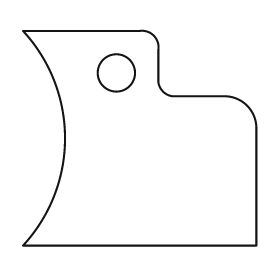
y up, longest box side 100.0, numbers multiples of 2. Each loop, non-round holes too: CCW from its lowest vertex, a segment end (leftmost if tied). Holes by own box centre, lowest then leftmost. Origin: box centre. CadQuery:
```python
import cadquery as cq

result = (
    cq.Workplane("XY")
    .moveTo(-50.0, -46.0)
    .lineTo(50.0, -46.0)
    .lineTo(50.0, 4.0)
    .threePointArc((46.0, 14.0), (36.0, 18.0))
    .lineTo(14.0, 18.0)
    .threePointArc((10.0, 20.0), (8.0, 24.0))
    .lineTo(8.0, 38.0)
    .threePointArc((6.0, 44.0), (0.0, 46.0))
    .lineTo(-50.0, 46.0)
    .threePointArc((-32.0, 0.0), (-50.0, -46.0))
    .close()
    .moveTo(-10.0, 28.0)
    .circle(8.0)
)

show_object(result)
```